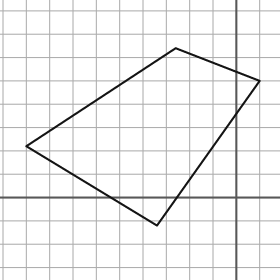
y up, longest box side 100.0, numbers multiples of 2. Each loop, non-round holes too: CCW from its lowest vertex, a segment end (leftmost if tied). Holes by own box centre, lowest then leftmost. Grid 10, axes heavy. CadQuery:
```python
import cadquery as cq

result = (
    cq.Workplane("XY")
    .moveTo(-34.0, -12.0)
    .lineTo(10.0, 50.0)
    .lineTo(-26.0, 64.0)
    .lineTo(-90.0, 22.0)
    .close()
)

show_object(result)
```